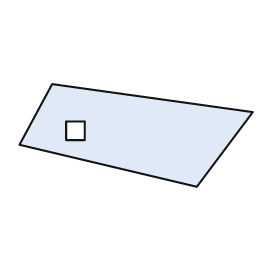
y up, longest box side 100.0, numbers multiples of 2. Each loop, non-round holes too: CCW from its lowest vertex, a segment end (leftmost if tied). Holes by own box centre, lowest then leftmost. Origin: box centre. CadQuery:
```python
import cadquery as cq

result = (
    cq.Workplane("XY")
    .moveTo(26.0, -22.0)
    .lineTo(50.0, 10.0)
    .lineTo(-36.0, 22.0)
    .lineTo(-50.0, -4.0)
    .close()
    .moveTo(-30.0, -2.0)
    .lineTo(-22.0, -2.0)
    .lineTo(-22.0, 6.0)
    .lineTo(-30.0, 6.0)
    .close()
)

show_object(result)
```